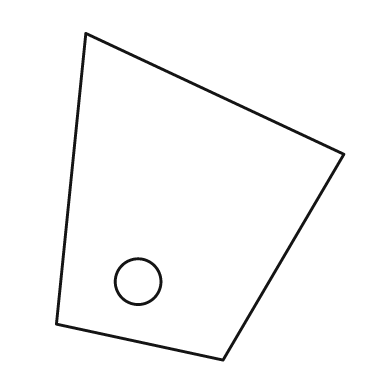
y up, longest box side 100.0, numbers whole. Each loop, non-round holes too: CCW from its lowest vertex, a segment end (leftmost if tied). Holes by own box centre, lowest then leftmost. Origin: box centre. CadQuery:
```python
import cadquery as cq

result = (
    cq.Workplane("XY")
    .moveTo(7.0, -50.0)
    .lineTo(44.0, 13.0)
    .lineTo(-35.0, 50.0)
    .lineTo(-44.0, -39.0)
    .close()
    .moveTo(-19.0, -26.0)
    .circle(7.0)
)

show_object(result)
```